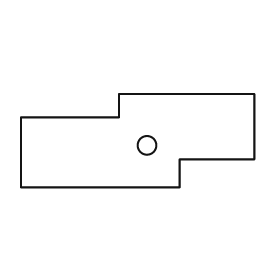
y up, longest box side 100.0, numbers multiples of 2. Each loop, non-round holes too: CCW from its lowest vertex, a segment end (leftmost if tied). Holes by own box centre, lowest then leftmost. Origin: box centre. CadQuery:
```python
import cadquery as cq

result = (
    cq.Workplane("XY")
    .moveTo(-50.0, -20.0)
    .lineTo(18.0, -20.0)
    .lineTo(18.0, -8.0)
    .lineTo(50.0, -8.0)
    .lineTo(50.0, 20.0)
    .lineTo(-8.0, 20.0)
    .lineTo(-8.0, 10.0)
    .lineTo(-50.0, 10.0)
    .close()
    .moveTo(4.0, -2.0)
    .circle(4.0)
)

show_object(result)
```